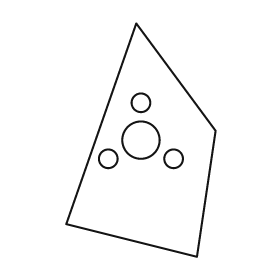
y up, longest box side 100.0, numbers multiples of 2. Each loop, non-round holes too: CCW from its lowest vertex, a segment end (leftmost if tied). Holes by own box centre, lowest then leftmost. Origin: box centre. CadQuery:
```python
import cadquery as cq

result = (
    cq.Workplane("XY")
    .moveTo(24.0, -50.0)
    .lineTo(32.0, 4.0)
    .lineTo(-2.0, 50.0)
    .lineTo(-32.0, -36.0)
    .close()
    .moveTo(-14.0, -8.0)
    .circle(4.0)
    .moveTo(14.0, -8.0)
    .circle(4.0)
    .moveTo(0.0, 0.0)
    .circle(8.0)
    .moveTo(0.0, 16.0)
    .circle(4.0)
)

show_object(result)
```